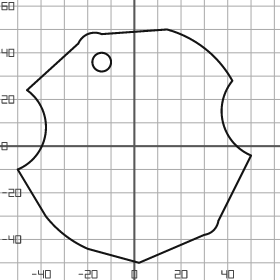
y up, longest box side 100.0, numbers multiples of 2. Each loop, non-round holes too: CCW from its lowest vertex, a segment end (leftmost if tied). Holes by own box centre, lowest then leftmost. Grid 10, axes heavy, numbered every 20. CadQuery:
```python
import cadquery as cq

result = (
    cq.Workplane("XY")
    .moveTo(2.0, -50.0)
    .lineTo(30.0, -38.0)
    .threePointArc((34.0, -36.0), (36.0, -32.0))
    .lineTo(50.0, -4.0)
    .threePointArc((38.0, 10.0), (42.0, 28.0))
    .threePointArc((30.0, 42.0), (14.0, 50.0))
    .lineTo(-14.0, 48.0)
    .threePointArc((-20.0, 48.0), (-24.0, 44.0))
    .lineTo(-46.0, 24.0)
    .threePointArc((-38.0, 6.0), (-50.0, -10.0))
    .lineTo(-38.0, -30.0)
    .threePointArc((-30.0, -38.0), (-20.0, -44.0))
    .close()
    .moveTo(-14.0, 36.0)
    .circle(4.0)
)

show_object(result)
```